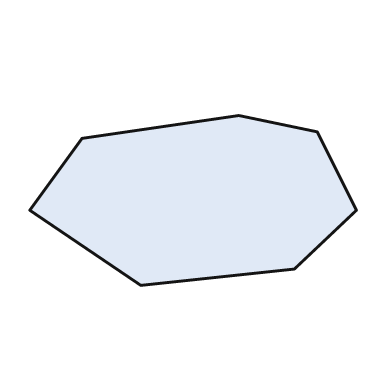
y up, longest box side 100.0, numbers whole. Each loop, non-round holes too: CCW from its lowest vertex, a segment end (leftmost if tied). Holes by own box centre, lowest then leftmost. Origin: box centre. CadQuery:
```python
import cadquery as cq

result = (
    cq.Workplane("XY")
    .moveTo(-16.0, -26.0)
    .lineTo(31.0, -21.0)
    .lineTo(50.0, -3.0)
    .lineTo(38.0, 21.0)
    .lineTo(14.0, 26.0)
    .lineTo(-34.0, 19.0)
    .lineTo(-50.0, -3.0)
    .close()
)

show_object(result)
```